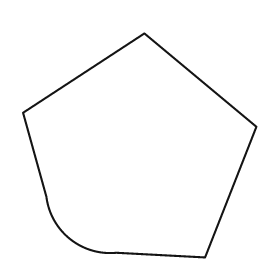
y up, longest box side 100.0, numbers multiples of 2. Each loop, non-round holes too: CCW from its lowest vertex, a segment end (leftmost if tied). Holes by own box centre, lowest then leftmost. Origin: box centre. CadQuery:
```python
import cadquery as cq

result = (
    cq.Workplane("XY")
    .moveTo(28.0, -48.0)
    .lineTo(50.0, 8.0)
    .lineTo(2.0, 48.0)
    .lineTo(-50.0, 14.0)
    .lineTo(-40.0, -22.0)
    .threePointArc((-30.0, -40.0), (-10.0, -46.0))
    .close()
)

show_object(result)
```